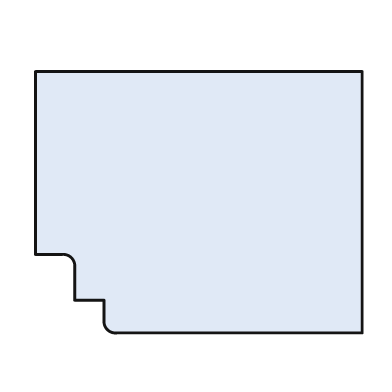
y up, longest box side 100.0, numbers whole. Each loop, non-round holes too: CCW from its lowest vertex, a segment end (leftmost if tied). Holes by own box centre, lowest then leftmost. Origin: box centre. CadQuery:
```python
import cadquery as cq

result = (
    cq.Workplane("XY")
    .moveTo(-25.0, -40.0)
    .lineTo(50.0, -40.0)
    .lineTo(50.0, 40.0)
    .lineTo(-50.0, 40.0)
    .lineTo(-50.0, -16.0)
    .lineTo(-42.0, -16.0)
    .threePointArc((-39.0, -17.0), (-38.0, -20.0))
    .lineTo(-38.0, -30.0)
    .lineTo(-29.0, -30.0)
    .lineTo(-29.0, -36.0)
    .threePointArc((-28.0, -39.0), (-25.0, -40.0))
    .close()
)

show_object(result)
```